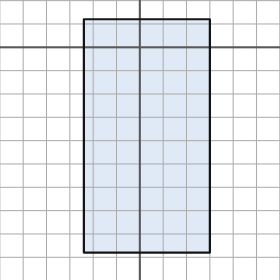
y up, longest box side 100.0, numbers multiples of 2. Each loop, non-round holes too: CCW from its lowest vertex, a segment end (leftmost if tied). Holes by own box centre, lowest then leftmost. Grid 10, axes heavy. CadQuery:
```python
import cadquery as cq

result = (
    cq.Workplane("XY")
    .moveTo(-24.0, -88.0)
    .lineTo(30.0, -88.0)
    .lineTo(30.0, 12.0)
    .lineTo(-24.0, 12.0)
    .close()
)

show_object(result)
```